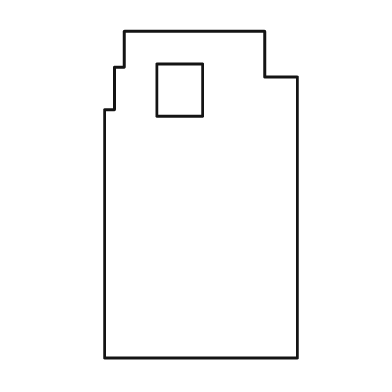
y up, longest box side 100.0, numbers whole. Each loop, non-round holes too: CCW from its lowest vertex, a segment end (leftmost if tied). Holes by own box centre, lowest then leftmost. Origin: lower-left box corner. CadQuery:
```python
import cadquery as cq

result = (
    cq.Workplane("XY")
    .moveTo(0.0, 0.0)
    .lineTo(59.0, 0.0)
    .lineTo(59.0, 86.0)
    .lineTo(49.0, 86.0)
    .lineTo(49.0, 100.0)
    .lineTo(6.0, 100.0)
    .lineTo(6.0, 89.0)
    .lineTo(3.0, 89.0)
    .lineTo(3.0, 76.0)
    .lineTo(0.0, 76.0)
    .close()
    .moveTo(16.0, 74.0)
    .lineTo(30.0, 74.0)
    .lineTo(30.0, 90.0)
    .lineTo(16.0, 90.0)
    .close()
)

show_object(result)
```